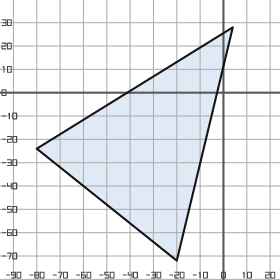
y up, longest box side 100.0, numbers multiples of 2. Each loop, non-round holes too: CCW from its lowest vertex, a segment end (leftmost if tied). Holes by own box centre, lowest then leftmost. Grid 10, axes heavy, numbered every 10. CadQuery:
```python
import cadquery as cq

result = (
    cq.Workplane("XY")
    .moveTo(-20.0, -72.0)
    .lineTo(4.0, 28.0)
    .lineTo(-80.0, -24.0)
    .close()
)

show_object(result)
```